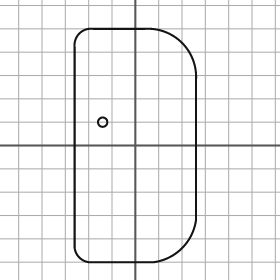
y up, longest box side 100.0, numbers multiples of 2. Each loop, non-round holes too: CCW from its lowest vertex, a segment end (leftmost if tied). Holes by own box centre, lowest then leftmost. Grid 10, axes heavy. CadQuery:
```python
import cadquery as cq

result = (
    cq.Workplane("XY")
    .moveTo(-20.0, -50.0)
    .lineTo(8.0, -50.0)
    .threePointArc((20.0, -44.0), (26.0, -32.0))
    .lineTo(26.0, 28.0)
    .threePointArc((20.0, 44.0), (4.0, 50.0))
    .lineTo(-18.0, 50.0)
    .threePointArc((-24.0, 48.0), (-26.0, 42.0))
    .lineTo(-26.0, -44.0)
    .threePointArc((-24.0, -48.0), (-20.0, -50.0))
    .close()
    .moveTo(-14.0, 10.0)
    .circle(2.0)
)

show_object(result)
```